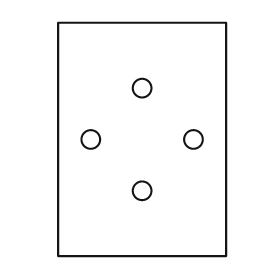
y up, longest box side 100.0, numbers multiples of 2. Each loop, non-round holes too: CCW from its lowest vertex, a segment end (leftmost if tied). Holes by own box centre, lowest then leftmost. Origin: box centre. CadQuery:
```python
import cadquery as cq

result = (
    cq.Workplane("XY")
    .moveTo(-36.0, -50.0)
    .lineTo(36.0, -50.0)
    .lineTo(36.0, 50.0)
    .lineTo(-36.0, 50.0)
    .close()
    .moveTo(0.0, -22.0)
    .circle(4.0)
    .moveTo(-22.0, 0.0)
    .circle(4.0)
    .moveTo(22.0, 0.0)
    .circle(4.0)
    .moveTo(0.0, 22.0)
    .circle(4.0)
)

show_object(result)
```